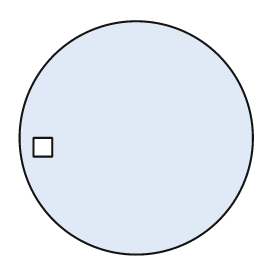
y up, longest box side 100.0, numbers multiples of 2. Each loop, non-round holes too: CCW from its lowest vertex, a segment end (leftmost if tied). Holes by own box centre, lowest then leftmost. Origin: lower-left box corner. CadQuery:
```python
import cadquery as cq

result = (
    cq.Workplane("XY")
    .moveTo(50.0, 50.0)
    .circle(50.0)
    .moveTo(6.0, 42.0)
    .lineTo(14.0, 42.0)
    .lineTo(14.0, 50.0)
    .lineTo(6.0, 50.0)
    .close()
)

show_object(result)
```